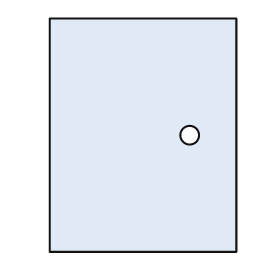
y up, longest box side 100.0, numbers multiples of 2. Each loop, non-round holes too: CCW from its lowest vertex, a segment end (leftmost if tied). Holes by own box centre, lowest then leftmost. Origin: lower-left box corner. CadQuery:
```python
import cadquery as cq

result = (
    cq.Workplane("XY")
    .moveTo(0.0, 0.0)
    .lineTo(80.0, 0.0)
    .lineTo(80.0, 100.0)
    .lineTo(0.0, 100.0)
    .close()
    .moveTo(60.0, 50.0)
    .circle(4.0)
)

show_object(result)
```